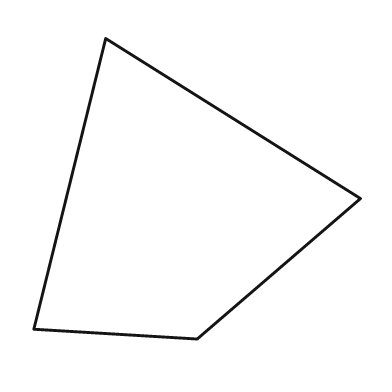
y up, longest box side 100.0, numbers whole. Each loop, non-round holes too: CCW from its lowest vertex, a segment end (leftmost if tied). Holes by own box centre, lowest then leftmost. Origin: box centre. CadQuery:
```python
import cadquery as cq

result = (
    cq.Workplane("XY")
    .moveTo(0.0, -46.0)
    .lineTo(50.0, -3.0)
    .lineTo(-28.0, 46.0)
    .lineTo(-50.0, -43.0)
    .close()
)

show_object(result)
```